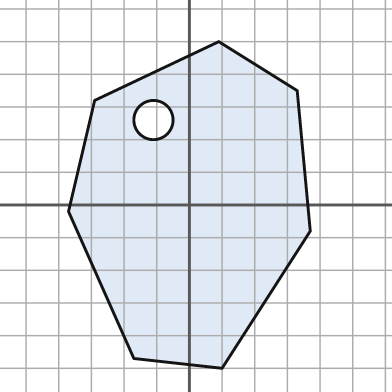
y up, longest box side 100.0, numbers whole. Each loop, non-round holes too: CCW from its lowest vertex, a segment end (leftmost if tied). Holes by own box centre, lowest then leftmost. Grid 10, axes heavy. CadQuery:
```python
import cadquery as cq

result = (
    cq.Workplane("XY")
    .moveTo(10.0, -50.0)
    .lineTo(37.0, -8.0)
    .lineTo(33.0, 35.0)
    .lineTo(9.0, 50.0)
    .lineTo(-29.0, 32.0)
    .lineTo(-37.0, -2.0)
    .lineTo(-17.0, -47.0)
    .close()
    .moveTo(-11.0, 26.0)
    .circle(6.0)
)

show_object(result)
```